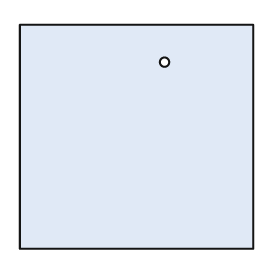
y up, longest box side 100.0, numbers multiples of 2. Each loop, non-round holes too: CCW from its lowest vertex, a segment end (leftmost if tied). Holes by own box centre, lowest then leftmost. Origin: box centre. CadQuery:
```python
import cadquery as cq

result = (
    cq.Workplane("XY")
    .moveTo(-50.0, -48.0)
    .lineTo(50.0, -48.0)
    .lineTo(50.0, 48.0)
    .lineTo(-50.0, 48.0)
    .close()
    .moveTo(12.0, 32.0)
    .circle(2.0)
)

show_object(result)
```